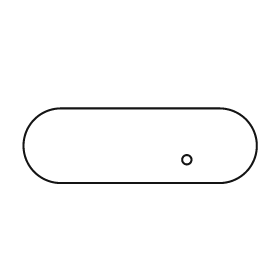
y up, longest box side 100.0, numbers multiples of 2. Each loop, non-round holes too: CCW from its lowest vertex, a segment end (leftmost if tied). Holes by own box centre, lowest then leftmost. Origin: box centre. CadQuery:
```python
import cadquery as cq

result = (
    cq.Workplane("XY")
    .moveTo(-34.0, -16.0)
    .lineTo(34.0, -16.0)
    .threePointArc((50.0, 0.0), (34.0, 16.0))
    .lineTo(-34.0, 16.0)
    .threePointArc((-50.0, 0.0), (-34.0, -16.0))
    .close()
    .moveTo(20.0, -6.0)
    .circle(2.0)
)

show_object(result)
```